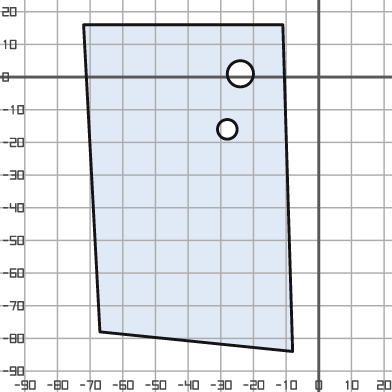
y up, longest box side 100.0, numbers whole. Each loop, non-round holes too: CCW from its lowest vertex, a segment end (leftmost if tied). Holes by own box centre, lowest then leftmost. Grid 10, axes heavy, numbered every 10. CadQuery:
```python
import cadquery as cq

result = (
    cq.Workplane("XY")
    .moveTo(-8.0, -84.0)
    .lineTo(-11.0, 16.0)
    .lineTo(-72.0, 16.0)
    .lineTo(-67.0, -78.0)
    .close()
    .moveTo(-28.0, -16.0)
    .circle(3.0)
    .moveTo(-24.0, 1.0)
    .circle(4.0)
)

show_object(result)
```